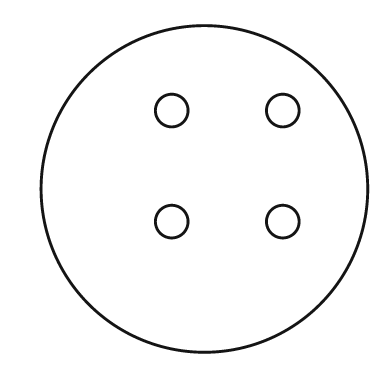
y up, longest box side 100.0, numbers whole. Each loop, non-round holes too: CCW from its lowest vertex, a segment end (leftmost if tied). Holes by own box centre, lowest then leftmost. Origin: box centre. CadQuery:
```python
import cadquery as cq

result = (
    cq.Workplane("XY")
    .moveTo(0.0, 0.0)
    .circle(50.0)
    .moveTo(-10.0, -10.0)
    .circle(5.0)
    .moveTo(24.0, -10.0)
    .circle(5.0)
    .moveTo(-10.0, 24.0)
    .circle(5.0)
    .moveTo(24.0, 24.0)
    .circle(5.0)
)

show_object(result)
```